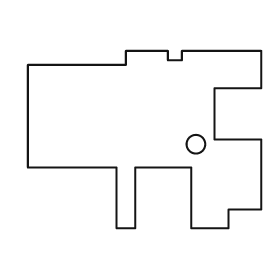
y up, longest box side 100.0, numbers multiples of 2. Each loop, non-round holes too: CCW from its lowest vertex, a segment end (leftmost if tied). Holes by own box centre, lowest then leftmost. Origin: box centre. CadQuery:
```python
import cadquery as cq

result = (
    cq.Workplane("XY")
    .moveTo(-12.0, -38.0)
    .lineTo(-4.0, -38.0)
    .lineTo(-4.0, -12.0)
    .lineTo(20.0, -12.0)
    .lineTo(20.0, -38.0)
    .lineTo(36.0, -38.0)
    .lineTo(36.0, -30.0)
    .lineTo(50.0, -30.0)
    .lineTo(50.0, 0.0)
    .lineTo(30.0, 0.0)
    .lineTo(30.0, 22.0)
    .lineTo(50.0, 22.0)
    .lineTo(50.0, 38.0)
    .lineTo(16.0, 38.0)
    .lineTo(16.0, 34.0)
    .lineTo(10.0, 34.0)
    .lineTo(10.0, 38.0)
    .lineTo(-8.0, 38.0)
    .lineTo(-8.0, 32.0)
    .lineTo(-50.0, 32.0)
    .lineTo(-50.0, -12.0)
    .lineTo(-12.0, -12.0)
    .close()
    .moveTo(22.0, -2.0)
    .circle(4.0)
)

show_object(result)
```